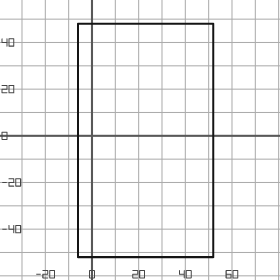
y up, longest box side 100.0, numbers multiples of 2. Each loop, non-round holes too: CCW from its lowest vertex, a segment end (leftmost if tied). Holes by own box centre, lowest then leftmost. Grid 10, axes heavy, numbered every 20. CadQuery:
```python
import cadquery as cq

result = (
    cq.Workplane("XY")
    .moveTo(-6.0, -52.0)
    .lineTo(52.0, -52.0)
    .lineTo(52.0, 48.0)
    .lineTo(-6.0, 48.0)
    .close()
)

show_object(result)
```